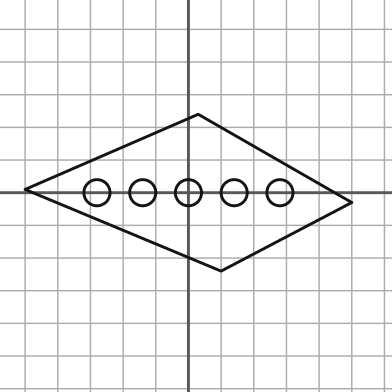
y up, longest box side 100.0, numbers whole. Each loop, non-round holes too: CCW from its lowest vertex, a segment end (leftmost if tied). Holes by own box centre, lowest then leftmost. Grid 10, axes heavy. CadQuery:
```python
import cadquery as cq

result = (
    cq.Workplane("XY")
    .moveTo(10.0, -24.0)
    .lineTo(50.0, -3.0)
    .lineTo(3.0, 24.0)
    .lineTo(-50.0, 1.0)
    .close()
    .moveTo(-28.0, 0.0)
    .circle(4.0)
    .moveTo(-14.0, 0.0)
    .circle(4.0)
    .moveTo(0.0, 0.0)
    .circle(4.0)
    .moveTo(14.0, 0.0)
    .circle(4.0)
    .moveTo(28.0, 0.0)
    .circle(4.0)
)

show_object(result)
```